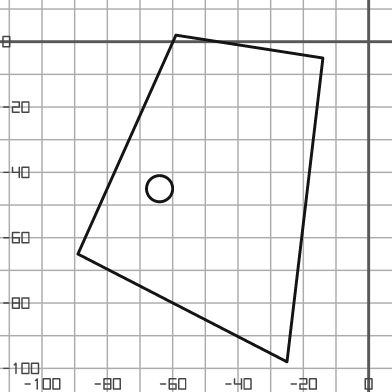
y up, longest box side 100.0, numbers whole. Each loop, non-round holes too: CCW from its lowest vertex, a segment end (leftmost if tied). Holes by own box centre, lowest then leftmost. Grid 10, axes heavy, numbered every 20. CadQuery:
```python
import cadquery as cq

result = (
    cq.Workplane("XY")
    .moveTo(-25.0, -98.0)
    .lineTo(-14.0, -5.0)
    .lineTo(-59.0, 2.0)
    .lineTo(-89.0, -65.0)
    .close()
    .moveTo(-64.0, -45.0)
    .circle(4.0)
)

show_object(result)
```